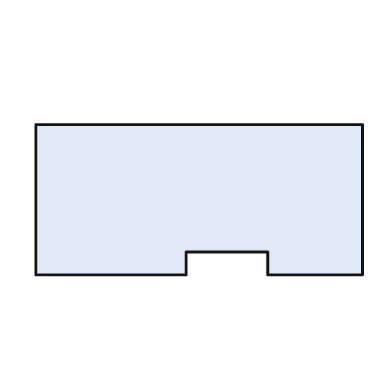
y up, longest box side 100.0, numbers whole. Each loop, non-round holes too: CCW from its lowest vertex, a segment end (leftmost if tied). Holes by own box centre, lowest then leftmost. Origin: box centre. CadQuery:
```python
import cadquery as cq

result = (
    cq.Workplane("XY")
    .moveTo(-50.0, -23.0)
    .lineTo(-4.0, -23.0)
    .lineTo(-4.0, -16.0)
    .lineTo(21.0, -16.0)
    .lineTo(21.0, -23.0)
    .lineTo(50.0, -23.0)
    .lineTo(50.0, 23.0)
    .lineTo(-50.0, 23.0)
    .close()
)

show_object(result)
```